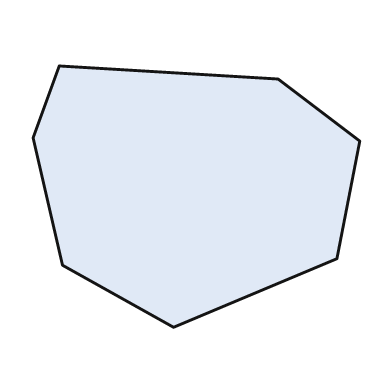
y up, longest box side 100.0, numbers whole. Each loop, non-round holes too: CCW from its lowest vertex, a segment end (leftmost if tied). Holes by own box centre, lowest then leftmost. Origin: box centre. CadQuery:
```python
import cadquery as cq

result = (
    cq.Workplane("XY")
    .moveTo(-7.0, -40.0)
    .lineTo(43.0, -19.0)
    .lineTo(50.0, 17.0)
    .lineTo(25.0, 36.0)
    .lineTo(-42.0, 40.0)
    .lineTo(-50.0, 18.0)
    .lineTo(-41.0, -21.0)
    .close()
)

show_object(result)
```